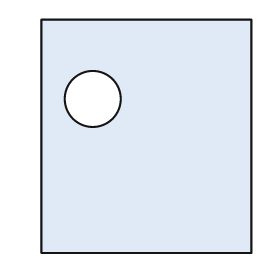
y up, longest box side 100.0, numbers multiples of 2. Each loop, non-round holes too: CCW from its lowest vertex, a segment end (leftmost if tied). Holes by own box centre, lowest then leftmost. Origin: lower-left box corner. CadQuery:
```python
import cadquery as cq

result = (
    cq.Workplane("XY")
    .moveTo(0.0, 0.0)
    .lineTo(90.0, 0.0)
    .lineTo(90.0, 100.0)
    .lineTo(0.0, 100.0)
    .close()
    .moveTo(22.0, 66.0)
    .circle(12.0)
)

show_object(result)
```